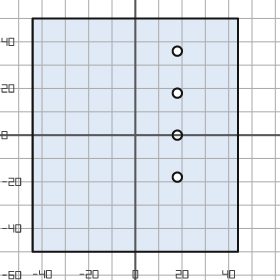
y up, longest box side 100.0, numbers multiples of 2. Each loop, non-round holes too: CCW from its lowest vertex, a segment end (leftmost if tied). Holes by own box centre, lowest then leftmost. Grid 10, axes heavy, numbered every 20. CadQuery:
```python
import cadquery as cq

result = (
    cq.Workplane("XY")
    .moveTo(-44.0, -50.0)
    .lineTo(44.0, -50.0)
    .lineTo(44.0, 50.0)
    .lineTo(-44.0, 50.0)
    .close()
    .moveTo(18.0, -18.0)
    .circle(2.0)
    .moveTo(18.0, 0.0)
    .circle(2.0)
    .moveTo(18.0, 18.0)
    .circle(2.0)
    .moveTo(18.0, 36.0)
    .circle(2.0)
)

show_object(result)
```